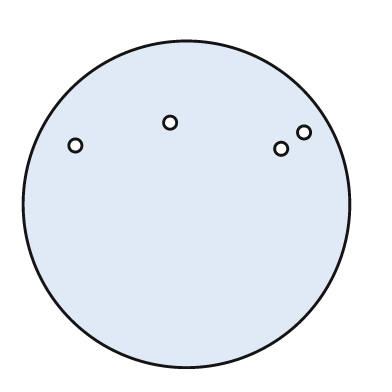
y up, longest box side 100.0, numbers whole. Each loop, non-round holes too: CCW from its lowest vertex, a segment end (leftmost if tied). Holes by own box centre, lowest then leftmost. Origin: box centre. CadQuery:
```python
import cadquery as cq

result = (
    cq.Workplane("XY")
    .moveTo(0.0, 0.0)
    .circle(50.0)
    .moveTo(29.0, 17.0)
    .circle(2.0)
    .moveTo(-34.0, 18.0)
    .circle(2.0)
    .moveTo(36.0, 22.0)
    .circle(2.0)
    .moveTo(-5.0, 25.0)
    .circle(2.0)
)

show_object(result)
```